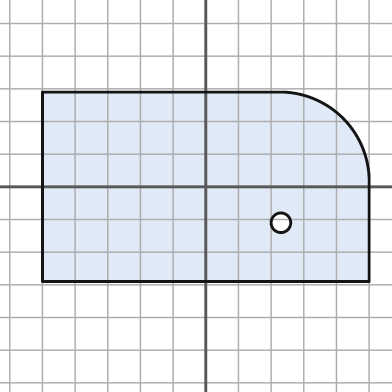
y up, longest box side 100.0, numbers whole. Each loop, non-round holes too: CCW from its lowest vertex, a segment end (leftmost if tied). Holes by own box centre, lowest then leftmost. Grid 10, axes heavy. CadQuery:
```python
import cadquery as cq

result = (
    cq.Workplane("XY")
    .moveTo(-50.0, -29.0)
    .lineTo(50.0, -29.0)
    .lineTo(50.0, 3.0)
    .threePointArc((42.0, 21.0), (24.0, 29.0))
    .lineTo(-50.0, 29.0)
    .close()
    .moveTo(23.0, -11.0)
    .circle(3.0)
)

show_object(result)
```